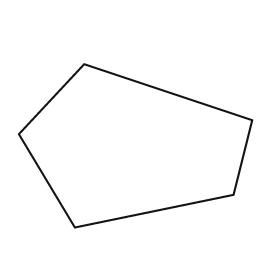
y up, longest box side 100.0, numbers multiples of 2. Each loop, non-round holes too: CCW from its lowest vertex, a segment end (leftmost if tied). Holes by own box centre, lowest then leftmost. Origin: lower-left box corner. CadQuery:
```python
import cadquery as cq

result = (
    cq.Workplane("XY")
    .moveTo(24.0, 0.0)
    .lineTo(92.0, 14.0)
    .lineTo(100.0, 46.0)
    .lineTo(28.0, 70.0)
    .lineTo(0.0, 40.0)
    .close()
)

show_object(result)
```